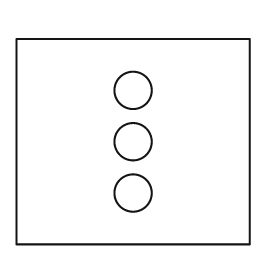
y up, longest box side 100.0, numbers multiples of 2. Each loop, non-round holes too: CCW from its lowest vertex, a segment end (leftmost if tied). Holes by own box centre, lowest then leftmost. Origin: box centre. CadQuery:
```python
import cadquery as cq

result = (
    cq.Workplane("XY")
    .moveTo(-50.0, -44.0)
    .lineTo(50.0, -44.0)
    .lineTo(50.0, 44.0)
    .lineTo(-50.0, 44.0)
    .close()
    .moveTo(0.0, -22.0)
    .circle(8.0)
    .moveTo(0.0, 0.0)
    .circle(8.0)
    .moveTo(0.0, 22.0)
    .circle(8.0)
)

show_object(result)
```